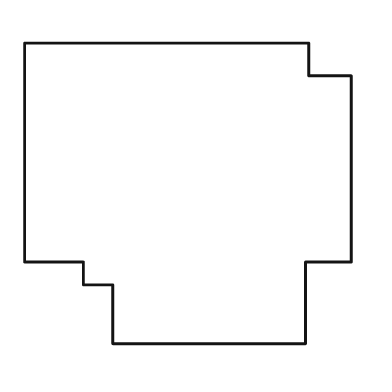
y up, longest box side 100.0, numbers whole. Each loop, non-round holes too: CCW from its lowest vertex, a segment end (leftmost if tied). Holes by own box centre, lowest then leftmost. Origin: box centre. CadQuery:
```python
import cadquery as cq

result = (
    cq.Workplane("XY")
    .moveTo(-23.0, -46.0)
    .lineTo(36.0, -46.0)
    .lineTo(36.0, -21.0)
    .lineTo(50.0, -21.0)
    .lineTo(50.0, 36.0)
    .lineTo(37.0, 36.0)
    .lineTo(37.0, 46.0)
    .lineTo(-50.0, 46.0)
    .lineTo(-50.0, -21.0)
    .lineTo(-32.0, -21.0)
    .lineTo(-32.0, -28.0)
    .lineTo(-23.0, -28.0)
    .close()
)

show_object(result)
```